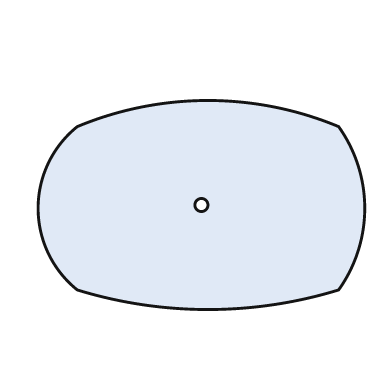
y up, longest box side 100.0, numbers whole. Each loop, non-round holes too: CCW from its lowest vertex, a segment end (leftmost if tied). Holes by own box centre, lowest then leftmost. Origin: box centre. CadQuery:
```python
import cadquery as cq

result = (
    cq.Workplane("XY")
    .moveTo(-38.0, -26.0)
    .threePointArc((2.0, -32.0), (42.0, -26.0))
    .threePointArc((50.0, -1.0), (42.0, 24.0))
    .threePointArc((2.0, 32.0), (-38.0, 24.0))
    .threePointArc((-50.0, -1.0), (-38.0, -26.0))
    .close()
    .moveTo(0.0, 0.0)
    .circle(2.0)
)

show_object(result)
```